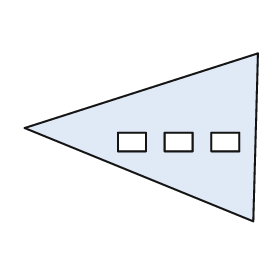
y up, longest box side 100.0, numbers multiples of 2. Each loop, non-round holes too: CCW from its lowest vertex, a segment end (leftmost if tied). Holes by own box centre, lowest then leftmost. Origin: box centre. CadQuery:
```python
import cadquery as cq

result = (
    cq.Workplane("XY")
    .moveTo(48.0, -36.0)
    .lineTo(50.0, 36.0)
    .lineTo(-50.0, 4.0)
    .close()
    .moveTo(-10.0, -6.0)
    .lineTo(2.0, -6.0)
    .lineTo(2.0, 2.0)
    .lineTo(-10.0, 2.0)
    .close()
    .moveTo(10.0, -6.0)
    .lineTo(22.0, -6.0)
    .lineTo(22.0, 2.0)
    .lineTo(10.0, 2.0)
    .close()
    .moveTo(30.0, -6.0)
    .lineTo(42.0, -6.0)
    .lineTo(42.0, 2.0)
    .lineTo(30.0, 2.0)
    .close()
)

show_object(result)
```